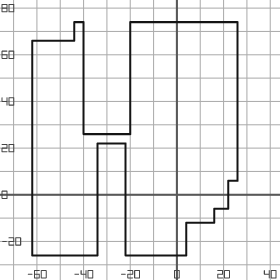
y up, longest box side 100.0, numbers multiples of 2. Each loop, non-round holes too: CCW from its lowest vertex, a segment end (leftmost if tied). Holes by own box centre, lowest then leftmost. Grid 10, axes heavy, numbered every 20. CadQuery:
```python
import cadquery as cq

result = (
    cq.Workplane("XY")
    .moveTo(-62.0, -26.0)
    .lineTo(-34.0, -26.0)
    .lineTo(-34.0, 22.0)
    .lineTo(-22.0, 22.0)
    .lineTo(-22.0, -26.0)
    .lineTo(4.0, -26.0)
    .lineTo(4.0, -12.0)
    .lineTo(16.0, -12.0)
    .lineTo(16.0, -6.0)
    .lineTo(22.0, -6.0)
    .lineTo(22.0, 6.0)
    .lineTo(26.0, 6.0)
    .lineTo(26.0, 74.0)
    .lineTo(-20.0, 74.0)
    .lineTo(-20.0, 26.0)
    .lineTo(-40.0, 26.0)
    .lineTo(-40.0, 74.0)
    .lineTo(-44.0, 74.0)
    .lineTo(-44.0, 66.0)
    .lineTo(-62.0, 66.0)
    .close()
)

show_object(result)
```